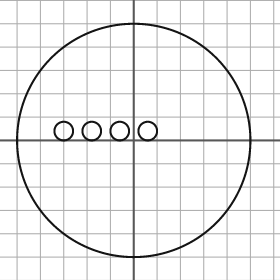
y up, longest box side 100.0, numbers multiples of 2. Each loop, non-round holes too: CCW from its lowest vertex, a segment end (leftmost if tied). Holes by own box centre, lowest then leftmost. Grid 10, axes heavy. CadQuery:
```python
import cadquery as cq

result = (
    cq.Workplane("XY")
    .moveTo(0.0, 0.0)
    .circle(50.0)
    .moveTo(-30.0, 4.0)
    .circle(4.0)
    .moveTo(-18.0, 4.0)
    .circle(4.0)
    .moveTo(-6.0, 4.0)
    .circle(4.0)
    .moveTo(6.0, 4.0)
    .circle(4.0)
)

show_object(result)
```